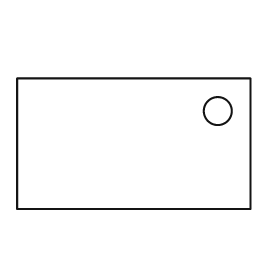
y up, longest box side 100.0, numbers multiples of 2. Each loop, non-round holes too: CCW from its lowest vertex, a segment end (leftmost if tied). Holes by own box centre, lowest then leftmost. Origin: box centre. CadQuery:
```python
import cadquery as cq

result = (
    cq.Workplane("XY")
    .moveTo(-50.0, -28.0)
    .lineTo(50.0, -28.0)
    .lineTo(50.0, 28.0)
    .lineTo(-50.0, 28.0)
    .close()
    .moveTo(36.0, 14.0)
    .circle(6.0)
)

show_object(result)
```